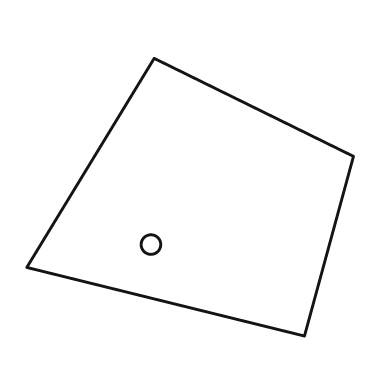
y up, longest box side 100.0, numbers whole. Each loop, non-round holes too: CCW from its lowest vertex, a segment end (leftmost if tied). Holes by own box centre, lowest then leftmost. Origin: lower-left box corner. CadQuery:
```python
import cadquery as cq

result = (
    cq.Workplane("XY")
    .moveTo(85.0, 0.0)
    .lineTo(100.0, 55.0)
    .lineTo(39.0, 85.0)
    .lineTo(0.0, 21.0)
    .close()
    .moveTo(38.0, 28.0)
    .circle(3.0)
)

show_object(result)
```